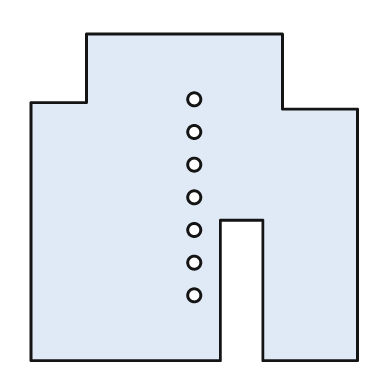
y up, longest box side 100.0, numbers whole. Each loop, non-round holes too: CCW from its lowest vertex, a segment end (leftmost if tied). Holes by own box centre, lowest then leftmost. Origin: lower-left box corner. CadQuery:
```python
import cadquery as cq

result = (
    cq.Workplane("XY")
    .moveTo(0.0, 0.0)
    .lineTo(58.0, 0.0)
    .lineTo(58.0, 43.0)
    .lineTo(71.0, 43.0)
    .lineTo(71.0, 0.0)
    .lineTo(100.0, 0.0)
    .lineTo(100.0, 77.0)
    .lineTo(77.0, 77.0)
    .lineTo(77.0, 100.0)
    .lineTo(17.0, 100.0)
    .lineTo(17.0, 79.0)
    .lineTo(0.0, 79.0)
    .close()
    .moveTo(50.0, 20.0)
    .circle(2.0)
    .moveTo(50.0, 30.0)
    .circle(2.0)
    .moveTo(50.0, 40.0)
    .circle(2.0)
    .moveTo(50.0, 50.0)
    .circle(2.0)
    .moveTo(50.0, 60.0)
    .circle(2.0)
    .moveTo(50.0, 70.0)
    .circle(2.0)
    .moveTo(50.0, 80.0)
    .circle(2.0)
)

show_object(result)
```